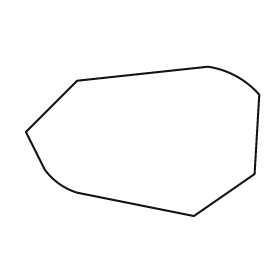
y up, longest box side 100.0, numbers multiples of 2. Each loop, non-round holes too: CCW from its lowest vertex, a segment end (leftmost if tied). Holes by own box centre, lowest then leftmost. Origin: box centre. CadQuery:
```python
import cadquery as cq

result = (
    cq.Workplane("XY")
    .moveTo(22.0, -32.0)
    .lineTo(48.0, -14.0)
    .lineTo(50.0, 20.0)
    .threePointArc((40.0, 28.0), (28.0, 32.0))
    .lineTo(-28.0, 26.0)
    .lineTo(-50.0, 4.0)
    .lineTo(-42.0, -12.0)
    .threePointArc((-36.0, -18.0), (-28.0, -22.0))
    .close()
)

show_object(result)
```